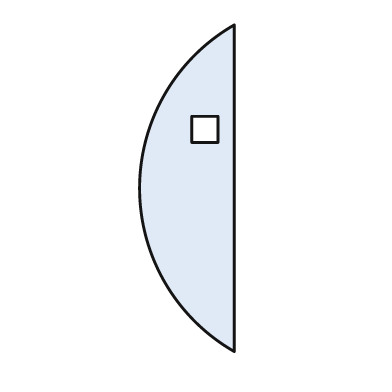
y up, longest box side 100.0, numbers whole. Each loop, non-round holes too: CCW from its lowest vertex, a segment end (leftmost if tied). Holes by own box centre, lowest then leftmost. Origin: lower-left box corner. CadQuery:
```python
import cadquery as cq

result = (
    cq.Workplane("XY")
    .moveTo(29.0, 0.0)
    .lineTo(29.0, 100.0)
    .threePointArc((0.0, 50.0), (29.0, 0.0))
    .close()
    .moveTo(16.0, 64.0)
    .lineTo(24.0, 64.0)
    .lineTo(24.0, 72.0)
    .lineTo(16.0, 72.0)
    .close()
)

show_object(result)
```